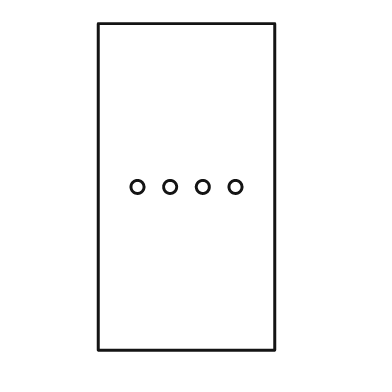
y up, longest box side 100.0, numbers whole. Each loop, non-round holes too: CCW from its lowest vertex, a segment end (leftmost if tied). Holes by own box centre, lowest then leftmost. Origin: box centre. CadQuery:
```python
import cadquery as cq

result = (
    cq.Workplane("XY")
    .moveTo(-27.0, -50.0)
    .lineTo(27.0, -50.0)
    .lineTo(27.0, 50.0)
    .lineTo(-27.0, 50.0)
    .close()
    .moveTo(-15.0, 0.0)
    .circle(2.0)
    .moveTo(-5.0, 0.0)
    .circle(2.0)
    .moveTo(5.0, 0.0)
    .circle(2.0)
    .moveTo(15.0, 0.0)
    .circle(2.0)
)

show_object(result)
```